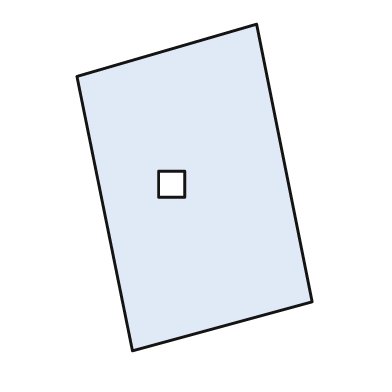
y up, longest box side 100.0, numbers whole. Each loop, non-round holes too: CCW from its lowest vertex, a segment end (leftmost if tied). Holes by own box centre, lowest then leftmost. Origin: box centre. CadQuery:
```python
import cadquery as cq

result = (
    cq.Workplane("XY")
    .moveTo(-19.0, -50.0)
    .lineTo(36.0, -35.0)
    .lineTo(19.0, 50.0)
    .lineTo(-36.0, 34.0)
    .close()
    .moveTo(-11.0, -3.0)
    .lineTo(-3.0, -3.0)
    .lineTo(-3.0, 5.0)
    .lineTo(-11.0, 5.0)
    .close()
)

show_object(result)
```